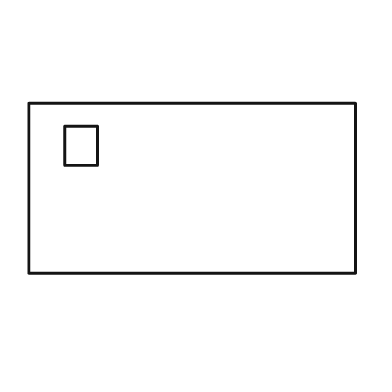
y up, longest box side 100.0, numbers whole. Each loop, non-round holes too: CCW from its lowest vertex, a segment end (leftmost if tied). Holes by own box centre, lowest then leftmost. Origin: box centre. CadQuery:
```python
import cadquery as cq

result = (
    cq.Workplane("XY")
    .moveTo(-50.0, -26.0)
    .lineTo(50.0, -26.0)
    .lineTo(50.0, 26.0)
    .lineTo(-50.0, 26.0)
    .close()
    .moveTo(-39.0, 7.0)
    .lineTo(-29.0, 7.0)
    .lineTo(-29.0, 19.0)
    .lineTo(-39.0, 19.0)
    .close()
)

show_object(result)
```